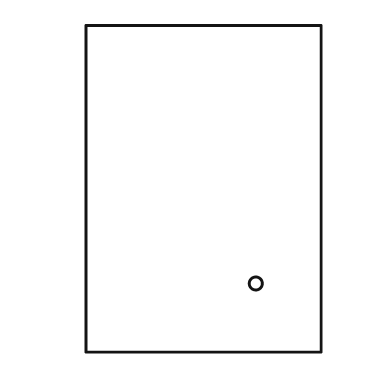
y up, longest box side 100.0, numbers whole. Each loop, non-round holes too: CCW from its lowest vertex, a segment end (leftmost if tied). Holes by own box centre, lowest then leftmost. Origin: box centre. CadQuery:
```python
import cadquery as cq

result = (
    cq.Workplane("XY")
    .moveTo(-36.0, -50.0)
    .lineTo(36.0, -50.0)
    .lineTo(36.0, 50.0)
    .lineTo(-36.0, 50.0)
    .close()
    .moveTo(16.0, -29.0)
    .circle(2.0)
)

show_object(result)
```